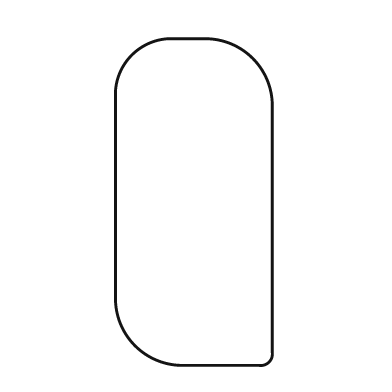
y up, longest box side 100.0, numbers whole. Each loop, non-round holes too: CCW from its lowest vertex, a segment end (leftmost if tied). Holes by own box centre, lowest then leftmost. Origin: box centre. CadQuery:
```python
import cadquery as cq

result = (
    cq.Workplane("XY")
    .moveTo(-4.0, -50.0)
    .lineTo(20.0, -50.0)
    .threePointArc((23.0, -49.0), (24.0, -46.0))
    .lineTo(24.0, 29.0)
    .threePointArc((18.0, 44.0), (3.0, 50.0))
    .lineTo(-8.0, 50.0)
    .threePointArc((-19.0, 45.0), (-24.0, 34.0))
    .lineTo(-24.0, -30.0)
    .threePointArc((-18.0, -44.0), (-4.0, -50.0))
    .close()
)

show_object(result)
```